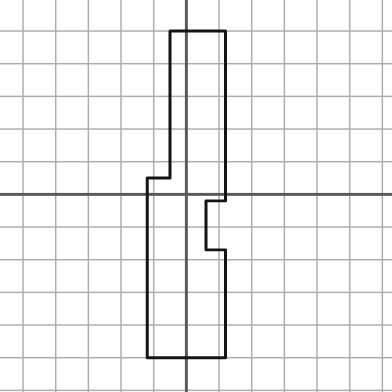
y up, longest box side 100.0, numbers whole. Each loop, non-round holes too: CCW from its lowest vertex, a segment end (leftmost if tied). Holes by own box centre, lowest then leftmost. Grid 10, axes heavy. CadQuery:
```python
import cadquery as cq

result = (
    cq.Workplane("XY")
    .moveTo(-12.0, -50.0)
    .lineTo(12.0, -50.0)
    .lineTo(12.0, -17.0)
    .lineTo(6.0, -17.0)
    .lineTo(6.0, -2.0)
    .lineTo(12.0, -2.0)
    .lineTo(12.0, 50.0)
    .lineTo(-5.0, 50.0)
    .lineTo(-5.0, 5.0)
    .lineTo(-12.0, 5.0)
    .close()
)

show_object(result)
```